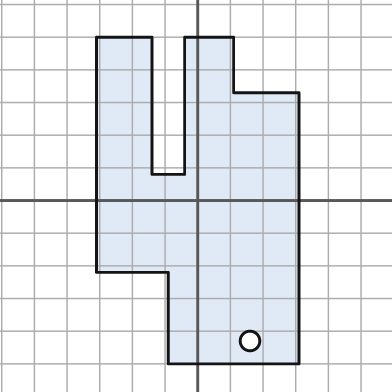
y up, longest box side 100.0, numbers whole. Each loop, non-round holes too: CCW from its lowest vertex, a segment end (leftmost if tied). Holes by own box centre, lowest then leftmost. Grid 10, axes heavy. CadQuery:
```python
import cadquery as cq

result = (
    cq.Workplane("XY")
    .moveTo(-9.0, -50.0)
    .lineTo(31.0, -50.0)
    .lineTo(31.0, 33.0)
    .lineTo(11.0, 33.0)
    .lineTo(11.0, 50.0)
    .lineTo(-4.0, 50.0)
    .lineTo(-4.0, 8.0)
    .lineTo(-14.0, 8.0)
    .lineTo(-14.0, 50.0)
    .lineTo(-31.0, 50.0)
    .lineTo(-31.0, -22.0)
    .lineTo(-9.0, -22.0)
    .close()
    .moveTo(16.0, -43.0)
    .circle(3.0)
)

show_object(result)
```